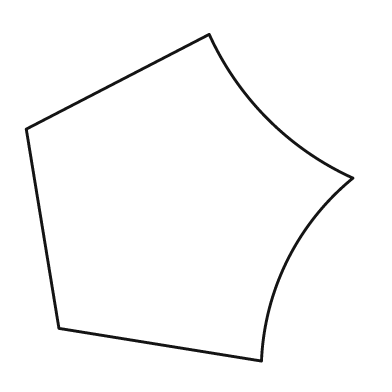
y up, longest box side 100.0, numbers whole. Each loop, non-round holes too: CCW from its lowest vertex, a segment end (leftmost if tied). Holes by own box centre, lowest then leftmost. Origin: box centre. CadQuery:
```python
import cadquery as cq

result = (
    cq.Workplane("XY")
    .moveTo(22.0, -50.0)
    .threePointArc((30.0, -19.0), (50.0, 6.0))
    .threePointArc((24.0, 24.0), (6.0, 50.0))
    .lineTo(-50.0, 21.0)
    .lineTo(-40.0, -40.0)
    .close()
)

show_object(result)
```